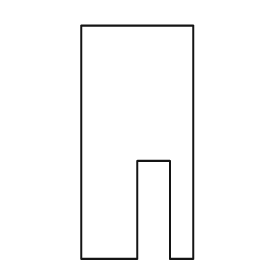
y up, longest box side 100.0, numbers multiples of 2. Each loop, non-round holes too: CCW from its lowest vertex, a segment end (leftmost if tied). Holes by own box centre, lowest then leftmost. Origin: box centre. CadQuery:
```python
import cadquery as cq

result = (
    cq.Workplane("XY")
    .moveTo(-24.0, -50.0)
    .lineTo(0.0, -50.0)
    .lineTo(0.0, -8.0)
    .lineTo(14.0, -8.0)
    .lineTo(14.0, -50.0)
    .lineTo(24.0, -50.0)
    .lineTo(24.0, 50.0)
    .lineTo(-24.0, 50.0)
    .close()
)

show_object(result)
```